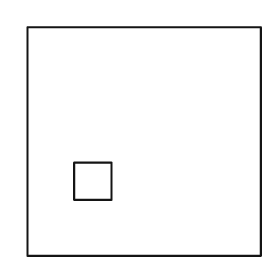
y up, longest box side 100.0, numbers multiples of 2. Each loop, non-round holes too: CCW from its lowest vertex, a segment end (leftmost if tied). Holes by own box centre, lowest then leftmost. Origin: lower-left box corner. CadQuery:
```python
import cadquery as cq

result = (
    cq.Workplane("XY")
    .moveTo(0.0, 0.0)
    .lineTo(100.0, 0.0)
    .lineTo(100.0, 98.0)
    .lineTo(0.0, 98.0)
    .close()
    .moveTo(20.0, 24.0)
    .lineTo(36.0, 24.0)
    .lineTo(36.0, 40.0)
    .lineTo(20.0, 40.0)
    .close()
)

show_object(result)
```